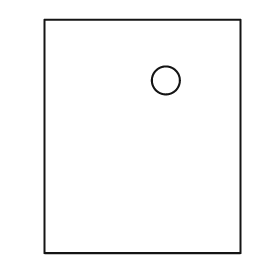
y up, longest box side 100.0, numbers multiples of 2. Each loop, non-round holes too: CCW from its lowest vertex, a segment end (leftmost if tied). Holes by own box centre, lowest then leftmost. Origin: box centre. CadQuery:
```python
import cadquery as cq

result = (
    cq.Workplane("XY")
    .moveTo(-42.0, -50.0)
    .lineTo(42.0, -50.0)
    .lineTo(42.0, 50.0)
    .lineTo(-42.0, 50.0)
    .close()
    .moveTo(10.0, 24.0)
    .circle(6.0)
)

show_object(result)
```